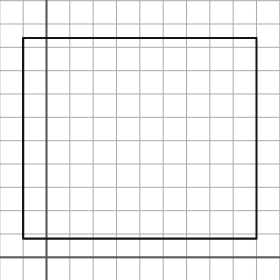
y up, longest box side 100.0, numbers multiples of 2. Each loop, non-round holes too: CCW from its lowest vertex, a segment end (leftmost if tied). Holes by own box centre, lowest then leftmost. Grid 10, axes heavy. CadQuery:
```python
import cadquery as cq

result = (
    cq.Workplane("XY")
    .moveTo(-10.0, 8.0)
    .lineTo(90.0, 8.0)
    .lineTo(90.0, 94.0)
    .lineTo(-10.0, 94.0)
    .close()
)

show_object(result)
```